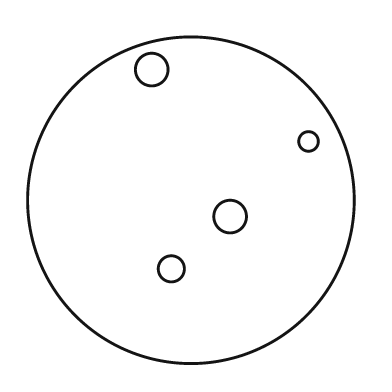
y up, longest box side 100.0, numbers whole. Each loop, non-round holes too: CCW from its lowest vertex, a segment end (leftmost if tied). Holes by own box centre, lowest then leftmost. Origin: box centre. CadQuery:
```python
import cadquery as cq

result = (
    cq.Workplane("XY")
    .moveTo(0.0, 0.0)
    .circle(50.0)
    .moveTo(-6.0, -21.0)
    .circle(4.0)
    .moveTo(12.0, -5.0)
    .circle(5.0)
    .moveTo(36.0, 18.0)
    .circle(3.0)
    .moveTo(-12.0, 40.0)
    .circle(5.0)
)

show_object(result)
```